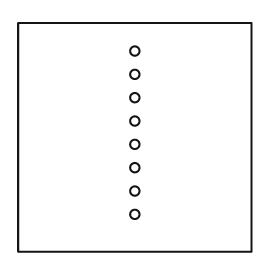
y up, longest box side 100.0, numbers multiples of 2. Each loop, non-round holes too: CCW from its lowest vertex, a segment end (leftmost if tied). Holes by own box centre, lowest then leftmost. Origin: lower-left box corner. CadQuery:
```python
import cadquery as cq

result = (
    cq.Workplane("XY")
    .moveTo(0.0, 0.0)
    .lineTo(100.0, 0.0)
    .lineTo(100.0, 98.0)
    .lineTo(0.0, 98.0)
    .close()
    .moveTo(50.0, 16.0)
    .circle(2.0)
    .moveTo(50.0, 26.0)
    .circle(2.0)
    .moveTo(50.0, 36.0)
    .circle(2.0)
    .moveTo(50.0, 46.0)
    .circle(2.0)
    .moveTo(50.0, 56.0)
    .circle(2.0)
    .moveTo(50.0, 66.0)
    .circle(2.0)
    .moveTo(50.0, 76.0)
    .circle(2.0)
    .moveTo(50.0, 86.0)
    .circle(2.0)
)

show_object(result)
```